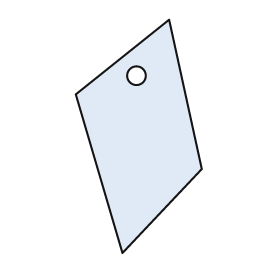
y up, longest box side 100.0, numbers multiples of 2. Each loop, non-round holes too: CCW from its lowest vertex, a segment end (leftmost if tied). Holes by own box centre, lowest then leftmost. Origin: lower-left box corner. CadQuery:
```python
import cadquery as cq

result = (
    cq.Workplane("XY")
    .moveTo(20.0, 0.0)
    .lineTo(54.0, 36.0)
    .lineTo(40.0, 100.0)
    .lineTo(0.0, 68.0)
    .close()
    .moveTo(26.0, 76.0)
    .circle(4.0)
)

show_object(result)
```